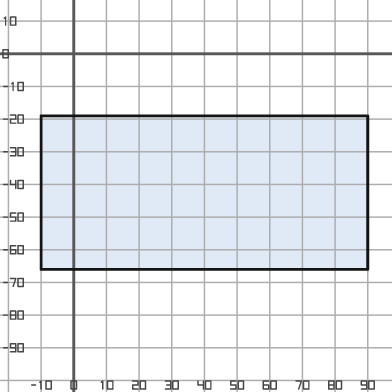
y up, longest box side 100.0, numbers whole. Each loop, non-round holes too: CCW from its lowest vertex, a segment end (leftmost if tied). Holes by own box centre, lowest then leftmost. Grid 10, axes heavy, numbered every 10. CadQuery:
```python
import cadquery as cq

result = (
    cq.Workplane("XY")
    .moveTo(-10.0, -66.0)
    .lineTo(90.0, -66.0)
    .lineTo(90.0, -19.0)
    .lineTo(-10.0, -19.0)
    .close()
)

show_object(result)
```